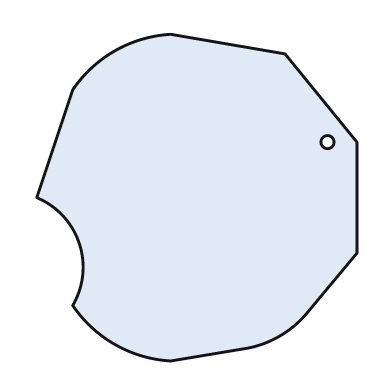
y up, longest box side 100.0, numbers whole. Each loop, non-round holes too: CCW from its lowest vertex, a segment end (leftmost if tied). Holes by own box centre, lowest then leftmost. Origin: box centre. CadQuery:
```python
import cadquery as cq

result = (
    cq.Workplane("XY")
    .moveTo(-8.0, -50.0)
    .lineTo(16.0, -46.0)
    .threePointArc((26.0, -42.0), (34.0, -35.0))
    .lineTo(49.0, -17.0)
    .lineTo(49.0, 17.0)
    .lineTo(27.0, 44.0)
    .lineTo(-8.0, 50.0)
    .threePointArc((-25.0, 45.0), (-38.0, 33.0))
    .lineTo(-49.0, 0.0)
    .threePointArc((-36.0, -14.0), (-38.0, -33.0))
    .threePointArc((-25.0, -45.0), (-8.0, -50.0))
    .close()
    .moveTo(40.0, 17.0)
    .circle(2.0)
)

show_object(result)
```